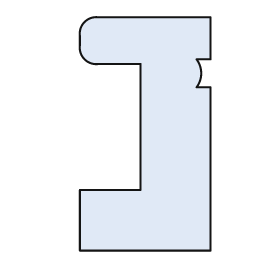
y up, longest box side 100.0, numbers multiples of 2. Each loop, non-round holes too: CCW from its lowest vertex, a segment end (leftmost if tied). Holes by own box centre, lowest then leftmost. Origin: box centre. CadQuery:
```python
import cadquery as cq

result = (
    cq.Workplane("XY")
    .moveTo(-28.0, -50.0)
    .lineTo(28.0, -50.0)
    .lineTo(28.0, 20.0)
    .lineTo(22.0, 20.0)
    .threePointArc((24.0, 26.0), (22.0, 32.0))
    .lineTo(28.0, 32.0)
    .lineTo(28.0, 50.0)
    .lineTo(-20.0, 50.0)
    .threePointArc((-26.0, 48.0), (-28.0, 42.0))
    .lineTo(-28.0, 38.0)
    .threePointArc((-26.0, 32.0), (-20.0, 30.0))
    .lineTo(-2.0, 30.0)
    .lineTo(-2.0, -24.0)
    .lineTo(-28.0, -24.0)
    .close()
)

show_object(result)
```